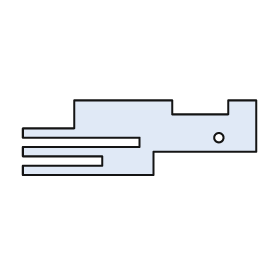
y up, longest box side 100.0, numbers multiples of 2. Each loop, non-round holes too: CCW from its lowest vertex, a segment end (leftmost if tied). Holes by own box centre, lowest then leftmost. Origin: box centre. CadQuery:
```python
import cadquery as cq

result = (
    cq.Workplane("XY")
    .moveTo(-50.0, -16.0)
    .lineTo(6.0, -16.0)
    .lineTo(6.0, -6.0)
    .lineTo(50.0, -6.0)
    .lineTo(50.0, 16.0)
    .lineTo(38.0, 16.0)
    .lineTo(38.0, 10.0)
    .lineTo(14.0, 10.0)
    .lineTo(14.0, 16.0)
    .lineTo(-28.0, 16.0)
    .lineTo(-28.0, 4.0)
    .lineTo(-50.0, 4.0)
    .lineTo(-50.0, 0.0)
    .lineTo(0.0, 0.0)
    .lineTo(0.0, -4.0)
    .lineTo(-50.0, -4.0)
    .lineTo(-50.0, -8.0)
    .lineTo(-16.0, -8.0)
    .lineTo(-16.0, -12.0)
    .lineTo(-50.0, -12.0)
    .close()
    .moveTo(34.0, 0.0)
    .circle(2.0)
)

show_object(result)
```